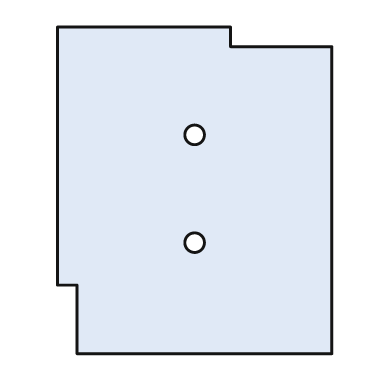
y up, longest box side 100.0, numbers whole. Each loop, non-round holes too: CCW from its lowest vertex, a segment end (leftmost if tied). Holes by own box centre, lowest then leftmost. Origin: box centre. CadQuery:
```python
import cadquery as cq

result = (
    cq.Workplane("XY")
    .moveTo(-36.0, -50.0)
    .lineTo(42.0, -50.0)
    .lineTo(42.0, 44.0)
    .lineTo(11.0, 44.0)
    .lineTo(11.0, 50.0)
    .lineTo(-42.0, 50.0)
    .lineTo(-42.0, -29.0)
    .lineTo(-36.0, -29.0)
    .close()
    .moveTo(0.0, -16.0)
    .circle(3.0)
    .moveTo(0.0, 17.0)
    .circle(3.0)
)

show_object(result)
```